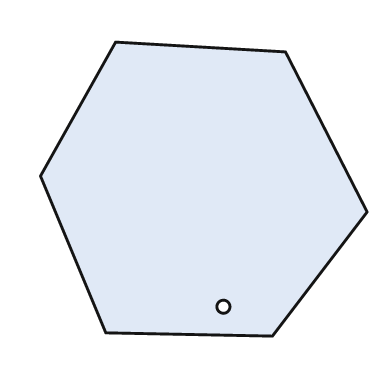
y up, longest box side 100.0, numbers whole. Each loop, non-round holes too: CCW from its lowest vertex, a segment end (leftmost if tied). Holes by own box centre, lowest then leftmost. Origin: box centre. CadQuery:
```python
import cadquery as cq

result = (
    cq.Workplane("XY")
    .moveTo(21.0, -45.0)
    .lineTo(50.0, -7.0)
    .lineTo(25.0, 42.0)
    .lineTo(-27.0, 45.0)
    .lineTo(-50.0, 4.0)
    .lineTo(-30.0, -44.0)
    .close()
    .moveTo(6.0, -36.0)
    .circle(2.0)
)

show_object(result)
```